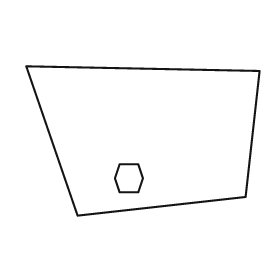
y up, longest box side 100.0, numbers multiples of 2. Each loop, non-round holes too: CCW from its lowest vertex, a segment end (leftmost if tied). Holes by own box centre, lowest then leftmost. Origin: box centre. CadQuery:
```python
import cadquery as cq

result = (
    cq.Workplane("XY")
    .moveTo(-28.0, -32.0)
    .lineTo(44.0, -24.0)
    .lineTo(50.0, 30.0)
    .lineTo(-50.0, 32.0)
    .close()
    .moveTo(-10.0, -22.0)
    .lineTo(-2.0, -22.0)
    .lineTo(0.0, -16.0)
    .lineTo(-2.0, -10.0)
    .lineTo(-10.0, -10.0)
    .lineTo(-12.0, -16.0)
    .close()
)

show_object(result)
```